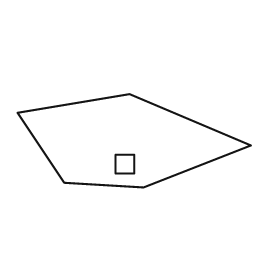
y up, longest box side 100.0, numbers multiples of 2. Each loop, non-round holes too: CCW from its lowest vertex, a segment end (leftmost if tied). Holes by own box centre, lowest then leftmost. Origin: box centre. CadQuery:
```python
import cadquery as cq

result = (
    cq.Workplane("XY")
    .moveTo(4.0, -20.0)
    .lineTo(50.0, -2.0)
    .lineTo(-2.0, 20.0)
    .lineTo(-50.0, 12.0)
    .lineTo(-30.0, -18.0)
    .close()
    .moveTo(-8.0, -14.0)
    .lineTo(0.0, -14.0)
    .lineTo(0.0, -6.0)
    .lineTo(-8.0, -6.0)
    .close()
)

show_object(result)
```